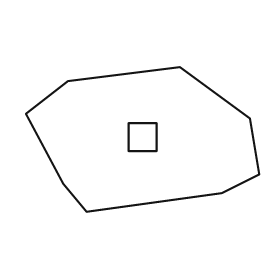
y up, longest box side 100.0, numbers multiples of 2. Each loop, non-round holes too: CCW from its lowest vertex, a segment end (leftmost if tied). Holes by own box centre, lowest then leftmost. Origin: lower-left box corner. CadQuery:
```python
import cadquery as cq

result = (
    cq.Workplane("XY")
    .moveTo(26.0, 0.0)
    .lineTo(84.0, 8.0)
    .lineTo(100.0, 16.0)
    .lineTo(96.0, 40.0)
    .lineTo(66.0, 62.0)
    .lineTo(18.0, 56.0)
    .lineTo(0.0, 42.0)
    .lineTo(16.0, 12.0)
    .close()
    .moveTo(44.0, 26.0)
    .lineTo(56.0, 26.0)
    .lineTo(56.0, 38.0)
    .lineTo(44.0, 38.0)
    .close()
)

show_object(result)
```